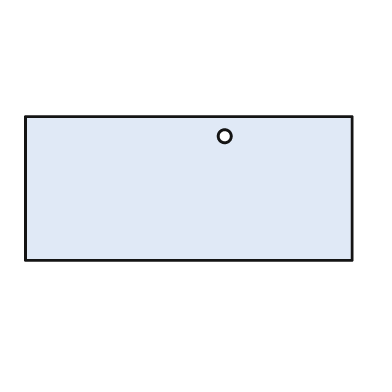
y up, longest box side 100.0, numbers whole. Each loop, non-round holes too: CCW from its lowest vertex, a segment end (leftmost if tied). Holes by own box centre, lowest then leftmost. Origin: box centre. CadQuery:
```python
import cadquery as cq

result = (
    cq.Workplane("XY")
    .moveTo(-50.0, -22.0)
    .lineTo(50.0, -22.0)
    .lineTo(50.0, 22.0)
    .lineTo(-50.0, 22.0)
    .close()
    .moveTo(11.0, 16.0)
    .circle(2.0)
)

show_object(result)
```